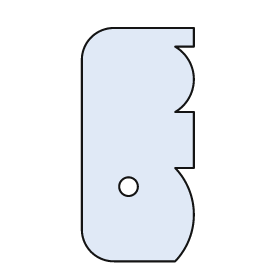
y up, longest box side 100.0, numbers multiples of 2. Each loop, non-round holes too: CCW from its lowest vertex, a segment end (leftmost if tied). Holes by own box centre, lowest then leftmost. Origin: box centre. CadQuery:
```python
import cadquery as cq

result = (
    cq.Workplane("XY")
    .moveTo(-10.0, -50.0)
    .lineTo(16.0, -50.0)
    .threePointArc((24.0, -30.0), (16.0, -10.0))
    .lineTo(24.0, -10.0)
    .lineTo(24.0, 14.0)
    .lineTo(16.0, 14.0)
    .threePointArc((24.0, 28.0), (16.0, 42.0))
    .lineTo(24.0, 42.0)
    .lineTo(24.0, 50.0)
    .lineTo(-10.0, 50.0)
    .threePointArc((-20.0, 46.0), (-24.0, 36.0))
    .lineTo(-24.0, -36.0)
    .threePointArc((-20.0, -46.0), (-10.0, -50.0))
    .close()
    .moveTo(-4.0, -18.0)
    .circle(4.0)
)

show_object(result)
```